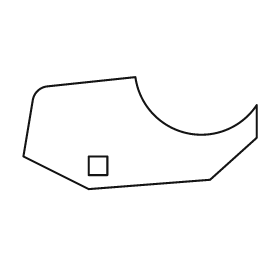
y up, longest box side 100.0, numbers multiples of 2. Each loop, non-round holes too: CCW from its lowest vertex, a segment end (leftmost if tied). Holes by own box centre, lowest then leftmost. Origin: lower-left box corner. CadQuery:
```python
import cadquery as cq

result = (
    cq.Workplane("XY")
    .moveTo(28.0, 0.0)
    .lineTo(80.0, 4.0)
    .lineTo(100.0, 22.0)
    .lineTo(100.0, 36.0)
    .threePointArc((70.0, 24.0), (48.0, 48.0))
    .lineTo(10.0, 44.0)
    .threePointArc((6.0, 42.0), (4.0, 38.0))
    .lineTo(0.0, 14.0)
    .close()
    .moveTo(28.0, 6.0)
    .lineTo(36.0, 6.0)
    .lineTo(36.0, 14.0)
    .lineTo(28.0, 14.0)
    .close()
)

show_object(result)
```